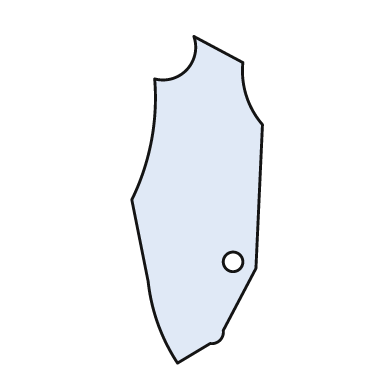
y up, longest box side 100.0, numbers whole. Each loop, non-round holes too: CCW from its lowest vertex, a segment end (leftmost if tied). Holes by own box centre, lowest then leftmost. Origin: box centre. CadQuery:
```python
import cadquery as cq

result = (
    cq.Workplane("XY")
    .moveTo(-6.0, -50.0)
    .lineTo(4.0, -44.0)
    .threePointArc((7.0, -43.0), (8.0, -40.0))
    .lineTo(18.0, -21.0)
    .lineTo(20.0, 23.0)
    .threePointArc((15.0, 32.0), (14.0, 42.0))
    .lineTo(-1.0, 50.0)
    .threePointArc((-3.0, 40.0), (-13.0, 37.0))
    .threePointArc((-14.0, 18.0), (-20.0, 0.0))
    .lineTo(-15.0, -25.0)
    .threePointArc((-12.0, -38.0), (-6.0, -50.0))
    .close()
    .moveTo(11.0, -19.0)
    .circle(3.0)
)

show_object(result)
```